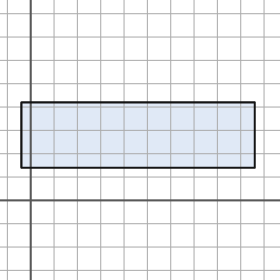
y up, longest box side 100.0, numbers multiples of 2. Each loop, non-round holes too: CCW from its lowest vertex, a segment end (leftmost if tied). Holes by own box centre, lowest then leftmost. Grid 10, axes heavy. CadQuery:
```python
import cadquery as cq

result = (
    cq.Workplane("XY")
    .moveTo(-4.0, 14.0)
    .lineTo(96.0, 14.0)
    .lineTo(96.0, 42.0)
    .lineTo(-4.0, 42.0)
    .close()
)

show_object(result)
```